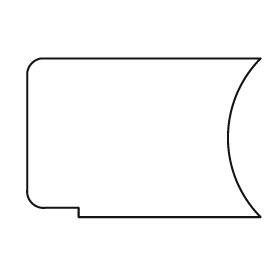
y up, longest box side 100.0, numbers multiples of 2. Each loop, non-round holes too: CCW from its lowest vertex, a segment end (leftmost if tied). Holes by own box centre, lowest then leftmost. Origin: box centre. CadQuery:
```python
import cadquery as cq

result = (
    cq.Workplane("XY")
    .moveTo(-28.0, -34.0)
    .lineTo(50.0, -34.0)
    .threePointArc((36.0, 0.0), (50.0, 34.0))
    .lineTo(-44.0, 34.0)
    .threePointArc((-48.0, 32.0), (-50.0, 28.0))
    .lineTo(-50.0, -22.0)
    .threePointArc((-48.0, -28.0), (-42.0, -30.0))
    .lineTo(-28.0, -30.0)
    .close()
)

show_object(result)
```